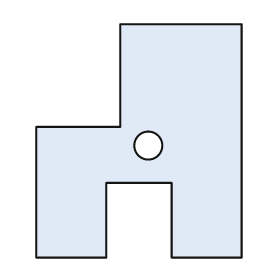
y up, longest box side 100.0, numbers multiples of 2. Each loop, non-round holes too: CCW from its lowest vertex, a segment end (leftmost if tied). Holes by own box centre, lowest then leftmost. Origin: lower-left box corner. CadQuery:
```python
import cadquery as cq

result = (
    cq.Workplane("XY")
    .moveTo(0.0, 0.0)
    .lineTo(30.0, 0.0)
    .lineTo(30.0, 32.0)
    .lineTo(58.0, 32.0)
    .lineTo(58.0, 0.0)
    .lineTo(88.0, 0.0)
    .lineTo(88.0, 100.0)
    .lineTo(36.0, 100.0)
    .lineTo(36.0, 56.0)
    .lineTo(0.0, 56.0)
    .close()
    .moveTo(48.0, 48.0)
    .circle(6.0)
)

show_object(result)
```